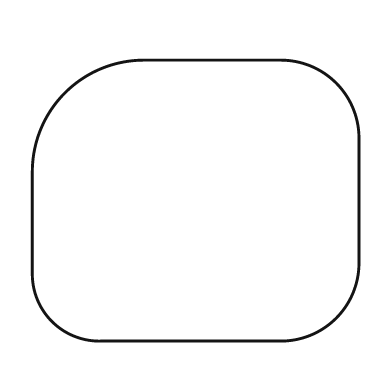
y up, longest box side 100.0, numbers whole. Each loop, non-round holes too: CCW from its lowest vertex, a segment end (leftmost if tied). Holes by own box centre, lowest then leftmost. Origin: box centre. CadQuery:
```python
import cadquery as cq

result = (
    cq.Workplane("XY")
    .moveTo(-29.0, -43.0)
    .lineTo(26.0, -43.0)
    .threePointArc((43.0, -36.0), (50.0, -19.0))
    .lineTo(50.0, 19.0)
    .threePointArc((43.0, 36.0), (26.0, 43.0))
    .lineTo(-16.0, 43.0)
    .threePointArc((-40.0, 33.0), (-50.0, 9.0))
    .lineTo(-50.0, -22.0)
    .threePointArc((-44.0, -37.0), (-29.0, -43.0))
    .close()
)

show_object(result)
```